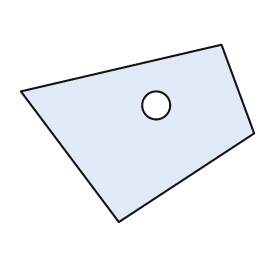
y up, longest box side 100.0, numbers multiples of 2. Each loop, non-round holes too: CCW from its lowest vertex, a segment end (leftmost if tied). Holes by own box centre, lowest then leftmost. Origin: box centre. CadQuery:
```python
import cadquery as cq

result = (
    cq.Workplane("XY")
    .moveTo(-8.0, -38.0)
    .lineTo(50.0, 0.0)
    .lineTo(36.0, 38.0)
    .lineTo(-50.0, 18.0)
    .close()
    .moveTo(8.0, 12.0)
    .circle(6.0)
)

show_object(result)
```